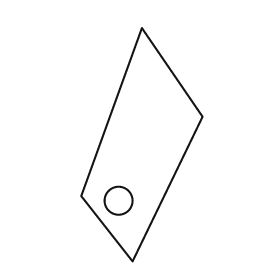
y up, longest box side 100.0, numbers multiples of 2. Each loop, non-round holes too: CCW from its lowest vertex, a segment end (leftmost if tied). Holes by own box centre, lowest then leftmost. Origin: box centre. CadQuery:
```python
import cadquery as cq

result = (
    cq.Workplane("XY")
    .moveTo(-4.0, -50.0)
    .lineTo(26.0, 12.0)
    .lineTo(0.0, 50.0)
    .lineTo(-26.0, -22.0)
    .close()
    .moveTo(-10.0, -24.0)
    .circle(6.0)
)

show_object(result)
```